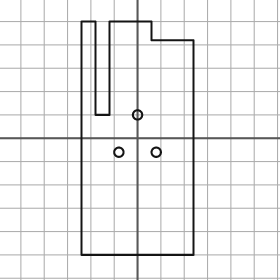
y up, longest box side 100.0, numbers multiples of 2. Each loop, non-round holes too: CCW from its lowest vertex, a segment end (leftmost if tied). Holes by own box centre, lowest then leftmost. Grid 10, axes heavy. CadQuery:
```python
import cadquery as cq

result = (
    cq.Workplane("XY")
    .moveTo(-24.0, -50.0)
    .lineTo(24.0, -50.0)
    .lineTo(24.0, 42.0)
    .lineTo(6.0, 42.0)
    .lineTo(6.0, 50.0)
    .lineTo(-12.0, 50.0)
    .lineTo(-12.0, 10.0)
    .lineTo(-18.0, 10.0)
    .lineTo(-18.0, 50.0)
    .lineTo(-24.0, 50.0)
    .close()
    .moveTo(-8.0, -6.0)
    .circle(2.0)
    .moveTo(8.0, -6.0)
    .circle(2.0)
    .moveTo(0.0, 10.0)
    .circle(2.0)
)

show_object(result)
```